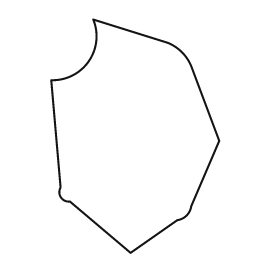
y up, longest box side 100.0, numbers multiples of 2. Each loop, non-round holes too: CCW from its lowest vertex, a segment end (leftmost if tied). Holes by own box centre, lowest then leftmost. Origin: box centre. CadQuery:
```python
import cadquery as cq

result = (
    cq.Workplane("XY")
    .moveTo(-2.0, -50.0)
    .lineTo(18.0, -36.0)
    .threePointArc((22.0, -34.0), (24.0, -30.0))
    .lineTo(36.0, -2.0)
    .lineTo(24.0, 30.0)
    .threePointArc((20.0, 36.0), (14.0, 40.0))
    .lineTo(-18.0, 50.0)
    .threePointArc((-20.0, 32.0), (-36.0, 24.0))
    .lineTo(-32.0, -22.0)
    .threePointArc((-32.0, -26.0), (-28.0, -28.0))
    .close()
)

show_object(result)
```